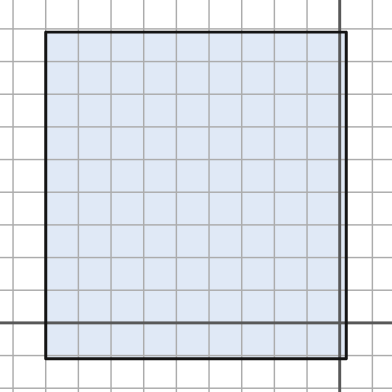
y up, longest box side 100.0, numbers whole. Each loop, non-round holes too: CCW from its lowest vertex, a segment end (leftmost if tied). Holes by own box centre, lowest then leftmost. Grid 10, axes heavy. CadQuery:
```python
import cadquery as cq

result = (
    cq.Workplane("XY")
    .moveTo(-90.0, -11.0)
    .lineTo(2.0, -11.0)
    .lineTo(2.0, 89.0)
    .lineTo(-90.0, 89.0)
    .close()
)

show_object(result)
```